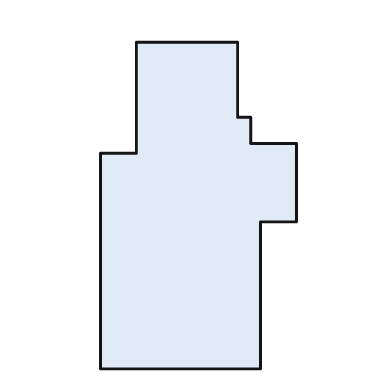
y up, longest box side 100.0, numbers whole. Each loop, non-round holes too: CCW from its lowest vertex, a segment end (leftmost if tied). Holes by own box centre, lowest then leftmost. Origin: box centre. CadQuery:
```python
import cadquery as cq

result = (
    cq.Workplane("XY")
    .moveTo(-30.0, -50.0)
    .lineTo(19.0, -50.0)
    .lineTo(19.0, -5.0)
    .lineTo(30.0, -5.0)
    .lineTo(30.0, 19.0)
    .lineTo(16.0, 19.0)
    .lineTo(16.0, 27.0)
    .lineTo(12.0, 27.0)
    .lineTo(12.0, 50.0)
    .lineTo(-19.0, 50.0)
    .lineTo(-19.0, 16.0)
    .lineTo(-30.0, 16.0)
    .close()
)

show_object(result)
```